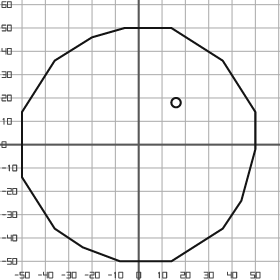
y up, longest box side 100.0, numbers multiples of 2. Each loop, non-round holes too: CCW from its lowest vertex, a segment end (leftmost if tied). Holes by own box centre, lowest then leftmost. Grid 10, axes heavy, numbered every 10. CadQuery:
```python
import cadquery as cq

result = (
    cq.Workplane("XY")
    .moveTo(-8.0, -50.0)
    .lineTo(14.0, -50.0)
    .lineTo(36.0, -36.0)
    .lineTo(44.0, -24.0)
    .lineTo(50.0, -2.0)
    .lineTo(50.0, 14.0)
    .lineTo(36.0, 36.0)
    .lineTo(14.0, 50.0)
    .lineTo(-6.0, 50.0)
    .lineTo(-20.0, 46.0)
    .lineTo(-36.0, 36.0)
    .lineTo(-50.0, 14.0)
    .lineTo(-50.0, -14.0)
    .lineTo(-36.0, -36.0)
    .lineTo(-24.0, -44.0)
    .close()
    .moveTo(16.0, 18.0)
    .circle(2.0)
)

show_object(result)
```